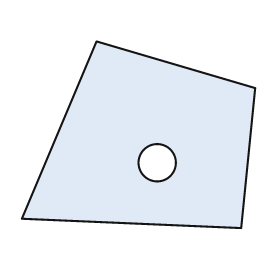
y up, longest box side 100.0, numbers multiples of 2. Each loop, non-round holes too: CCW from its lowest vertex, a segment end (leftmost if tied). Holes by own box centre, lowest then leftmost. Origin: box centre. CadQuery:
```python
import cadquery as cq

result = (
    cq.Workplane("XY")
    .moveTo(44.0, -40.0)
    .lineTo(50.0, 20.0)
    .lineTo(-18.0, 40.0)
    .lineTo(-50.0, -36.0)
    .close()
    .moveTo(8.0, -12.0)
    .circle(8.0)
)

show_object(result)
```